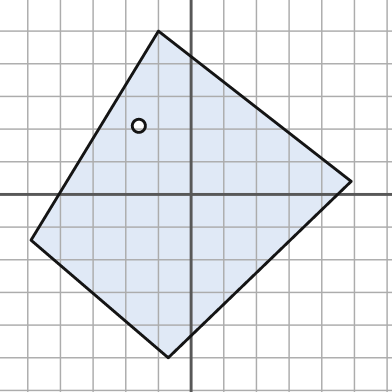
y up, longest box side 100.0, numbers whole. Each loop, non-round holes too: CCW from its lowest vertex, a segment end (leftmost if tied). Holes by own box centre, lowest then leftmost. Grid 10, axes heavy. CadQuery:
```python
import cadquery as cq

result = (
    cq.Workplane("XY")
    .moveTo(-7.0, -50.0)
    .lineTo(49.0, 4.0)
    .lineTo(-10.0, 50.0)
    .lineTo(-49.0, -14.0)
    .close()
    .moveTo(-16.0, 21.0)
    .circle(2.0)
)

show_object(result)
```